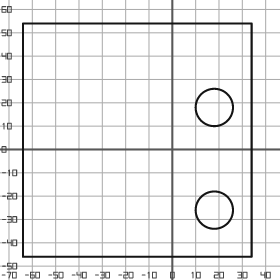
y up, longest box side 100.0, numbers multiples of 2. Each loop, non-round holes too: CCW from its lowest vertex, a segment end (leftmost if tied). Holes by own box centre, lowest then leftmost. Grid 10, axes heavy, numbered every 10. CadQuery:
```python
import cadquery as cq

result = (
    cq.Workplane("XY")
    .moveTo(-64.0, -46.0)
    .lineTo(34.0, -46.0)
    .lineTo(34.0, 54.0)
    .lineTo(-64.0, 54.0)
    .close()
    .moveTo(18.0, -26.0)
    .circle(8.0)
    .moveTo(18.0, 18.0)
    .circle(8.0)
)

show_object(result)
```